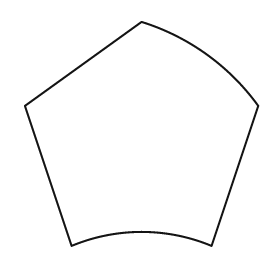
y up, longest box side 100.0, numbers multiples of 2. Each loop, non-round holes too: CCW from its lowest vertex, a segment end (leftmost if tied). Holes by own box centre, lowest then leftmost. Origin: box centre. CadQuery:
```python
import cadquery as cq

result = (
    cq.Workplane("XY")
    .moveTo(-30.0, -48.0)
    .threePointArc((0.0, -42.0), (30.0, -48.0))
    .lineTo(50.0, 12.0)
    .threePointArc((28.0, 34.0), (0.0, 48.0))
    .lineTo(-50.0, 12.0)
    .close()
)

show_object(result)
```